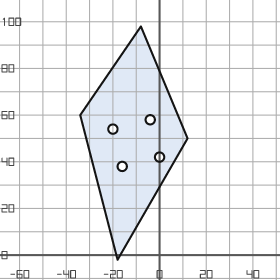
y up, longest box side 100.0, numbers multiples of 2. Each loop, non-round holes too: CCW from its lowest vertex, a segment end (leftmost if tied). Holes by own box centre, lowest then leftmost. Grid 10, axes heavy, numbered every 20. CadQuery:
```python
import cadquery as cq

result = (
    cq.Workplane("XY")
    .moveTo(-18.0, -2.0)
    .lineTo(12.0, 50.0)
    .lineTo(-8.0, 98.0)
    .lineTo(-34.0, 60.0)
    .close()
    .moveTo(-16.0, 38.0)
    .circle(2.0)
    .moveTo(0.0, 42.0)
    .circle(2.0)
    .moveTo(-20.0, 54.0)
    .circle(2.0)
    .moveTo(-4.0, 58.0)
    .circle(2.0)
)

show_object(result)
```